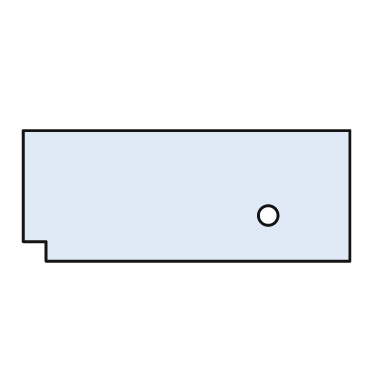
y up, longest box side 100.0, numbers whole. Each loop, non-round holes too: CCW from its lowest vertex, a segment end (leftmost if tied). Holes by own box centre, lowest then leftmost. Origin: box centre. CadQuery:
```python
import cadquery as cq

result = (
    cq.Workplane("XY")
    .moveTo(-43.0, -20.0)
    .lineTo(50.0, -20.0)
    .lineTo(50.0, 20.0)
    .lineTo(-50.0, 20.0)
    .lineTo(-50.0, -14.0)
    .lineTo(-43.0, -14.0)
    .close()
    .moveTo(25.0, -6.0)
    .circle(3.0)
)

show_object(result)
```